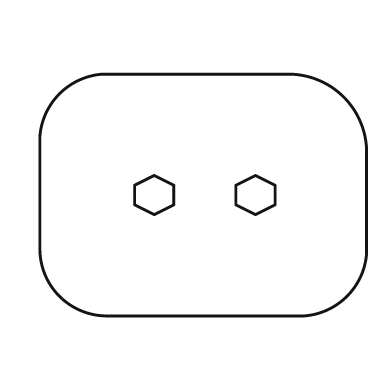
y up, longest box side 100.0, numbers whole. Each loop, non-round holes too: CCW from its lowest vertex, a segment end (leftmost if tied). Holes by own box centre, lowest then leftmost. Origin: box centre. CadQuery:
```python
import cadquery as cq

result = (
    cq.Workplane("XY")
    .moveTo(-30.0, -37.0)
    .lineTo(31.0, -37.0)
    .threePointArc((44.0, -31.0), (50.0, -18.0))
    .lineTo(50.0, 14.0)
    .threePointArc((43.0, 30.0), (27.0, 37.0))
    .lineTo(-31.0, 37.0)
    .threePointArc((-44.0, 31.0), (-50.0, 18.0))
    .lineTo(-50.0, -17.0)
    .threePointArc((-44.0, -31.0), (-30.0, -37.0))
    .close()
    .moveTo(-15.0, -6.0)
    .lineTo(-9.0, -3.0)
    .lineTo(-9.0, 3.0)
    .lineTo(-15.0, 6.0)
    .lineTo(-21.0, 3.0)
    .lineTo(-21.0, -3.0)
    .close()
    .moveTo(16.0, -6.0)
    .lineTo(22.0, -3.0)
    .lineTo(22.0, 3.0)
    .lineTo(16.0, 6.0)
    .lineTo(10.0, 3.0)
    .lineTo(10.0, -3.0)
    .close()
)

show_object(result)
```